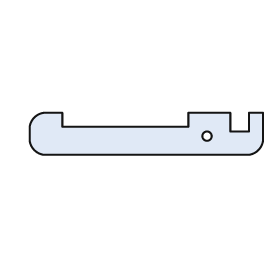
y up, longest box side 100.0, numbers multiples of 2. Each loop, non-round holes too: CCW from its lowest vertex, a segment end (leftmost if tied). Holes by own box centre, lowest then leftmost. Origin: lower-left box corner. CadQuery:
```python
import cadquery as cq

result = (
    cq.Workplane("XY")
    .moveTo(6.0, 0.0)
    .lineTo(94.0, 0.0)
    .threePointArc((98.0, 2.0), (100.0, 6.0))
    .lineTo(100.0, 18.0)
    .lineTo(94.0, 18.0)
    .lineTo(94.0, 10.0)
    .lineTo(86.0, 10.0)
    .lineTo(86.0, 18.0)
    .lineTo(68.0, 18.0)
    .lineTo(68.0, 12.0)
    .lineTo(14.0, 12.0)
    .lineTo(14.0, 18.0)
    .lineTo(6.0, 18.0)
    .threePointArc((2.0, 16.0), (0.0, 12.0))
    .lineTo(0.0, 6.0)
    .threePointArc((2.0, 2.0), (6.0, 0.0))
    .close()
    .moveTo(76.0, 8.0)
    .circle(2.0)
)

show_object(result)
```